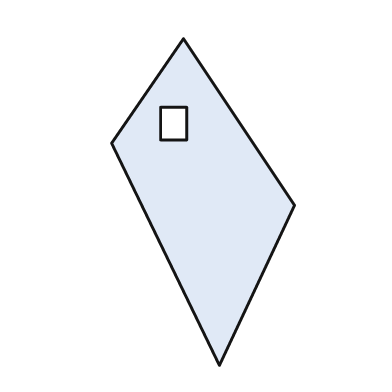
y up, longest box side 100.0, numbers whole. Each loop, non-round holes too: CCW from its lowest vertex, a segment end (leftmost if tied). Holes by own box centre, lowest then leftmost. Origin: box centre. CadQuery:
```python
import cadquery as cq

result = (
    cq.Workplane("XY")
    .moveTo(5.0, -50.0)
    .lineTo(28.0, -1.0)
    .lineTo(-6.0, 50.0)
    .lineTo(-28.0, 18.0)
    .close()
    .moveTo(-13.0, 19.0)
    .lineTo(-5.0, 19.0)
    .lineTo(-5.0, 29.0)
    .lineTo(-13.0, 29.0)
    .close()
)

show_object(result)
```